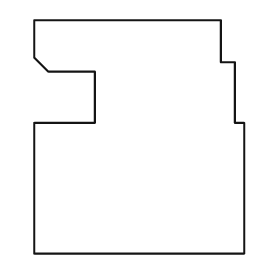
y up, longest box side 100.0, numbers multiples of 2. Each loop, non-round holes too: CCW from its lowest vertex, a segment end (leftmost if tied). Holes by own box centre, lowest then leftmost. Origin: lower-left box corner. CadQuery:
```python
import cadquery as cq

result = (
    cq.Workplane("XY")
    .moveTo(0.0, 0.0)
    .lineTo(90.0, 0.0)
    .lineTo(90.0, 56.0)
    .lineTo(86.0, 56.0)
    .lineTo(86.0, 82.0)
    .lineTo(80.0, 82.0)
    .lineTo(80.0, 100.0)
    .lineTo(0.0, 100.0)
    .lineTo(0.0, 84.0)
    .lineTo(6.0, 78.0)
    .lineTo(26.0, 78.0)
    .lineTo(26.0, 56.0)
    .lineTo(0.0, 56.0)
    .close()
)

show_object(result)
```